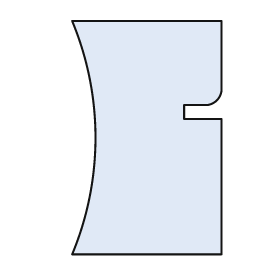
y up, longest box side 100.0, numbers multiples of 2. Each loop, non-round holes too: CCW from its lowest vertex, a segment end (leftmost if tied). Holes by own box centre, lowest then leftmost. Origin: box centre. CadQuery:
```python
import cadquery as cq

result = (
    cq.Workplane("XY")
    .moveTo(-32.0, -50.0)
    .lineTo(32.0, -50.0)
    .lineTo(32.0, 8.0)
    .lineTo(16.0, 8.0)
    .lineTo(16.0, 14.0)
    .lineTo(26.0, 14.0)
    .threePointArc((30.0, 16.0), (32.0, 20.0))
    .lineTo(32.0, 50.0)
    .lineTo(-32.0, 50.0)
    .threePointArc((-22.0, 0.0), (-32.0, -50.0))
    .close()
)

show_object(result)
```